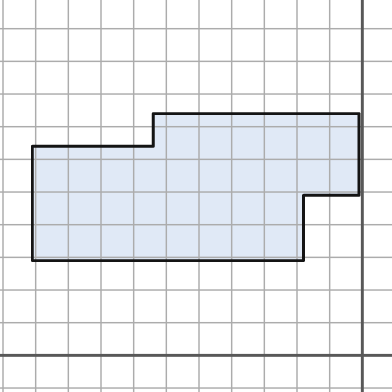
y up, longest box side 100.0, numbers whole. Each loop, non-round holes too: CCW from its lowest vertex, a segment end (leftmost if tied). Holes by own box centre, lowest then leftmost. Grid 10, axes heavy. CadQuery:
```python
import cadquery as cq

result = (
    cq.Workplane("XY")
    .moveTo(-101.0, 29.0)
    .lineTo(-18.0, 29.0)
    .lineTo(-18.0, 49.0)
    .lineTo(-1.0, 49.0)
    .lineTo(-1.0, 74.0)
    .lineTo(-64.0, 74.0)
    .lineTo(-64.0, 64.0)
    .lineTo(-101.0, 64.0)
    .close()
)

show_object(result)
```